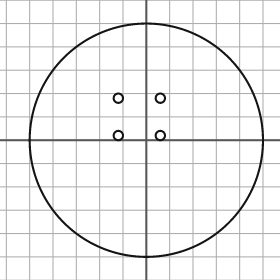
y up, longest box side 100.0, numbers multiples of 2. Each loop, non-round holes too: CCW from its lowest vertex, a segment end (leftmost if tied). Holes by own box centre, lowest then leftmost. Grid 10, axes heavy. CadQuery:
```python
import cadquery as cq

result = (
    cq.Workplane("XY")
    .moveTo(0.0, 0.0)
    .circle(50.0)
    .moveTo(-12.0, 2.0)
    .circle(2.0)
    .moveTo(6.0, 2.0)
    .circle(2.0)
    .moveTo(-12.0, 18.0)
    .circle(2.0)
    .moveTo(6.0, 18.0)
    .circle(2.0)
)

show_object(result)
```